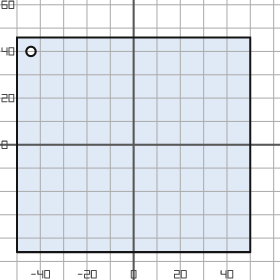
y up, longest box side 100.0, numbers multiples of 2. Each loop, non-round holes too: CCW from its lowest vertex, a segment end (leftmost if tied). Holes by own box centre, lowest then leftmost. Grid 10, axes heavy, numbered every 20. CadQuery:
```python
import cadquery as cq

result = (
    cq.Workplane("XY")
    .moveTo(-50.0, -46.0)
    .lineTo(50.0, -46.0)
    .lineTo(50.0, 46.0)
    .lineTo(-50.0, 46.0)
    .close()
    .moveTo(-44.0, 40.0)
    .circle(2.0)
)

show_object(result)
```